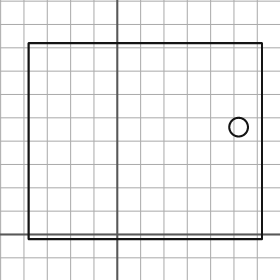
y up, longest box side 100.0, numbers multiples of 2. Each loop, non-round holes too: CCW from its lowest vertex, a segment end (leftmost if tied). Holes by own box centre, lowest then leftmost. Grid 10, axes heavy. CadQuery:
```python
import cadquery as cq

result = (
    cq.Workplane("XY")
    .moveTo(-38.0, -2.0)
    .lineTo(62.0, -2.0)
    .lineTo(62.0, 82.0)
    .lineTo(-38.0, 82.0)
    .close()
    .moveTo(52.0, 46.0)
    .circle(4.0)
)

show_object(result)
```